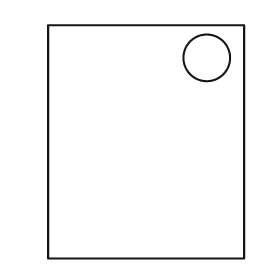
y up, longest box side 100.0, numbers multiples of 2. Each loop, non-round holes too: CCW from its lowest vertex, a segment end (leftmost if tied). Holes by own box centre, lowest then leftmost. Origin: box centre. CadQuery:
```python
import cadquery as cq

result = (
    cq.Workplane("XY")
    .moveTo(-42.0, -50.0)
    .lineTo(42.0, -50.0)
    .lineTo(42.0, 50.0)
    .lineTo(-42.0, 50.0)
    .close()
    .moveTo(26.0, 36.0)
    .circle(10.0)
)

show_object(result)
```